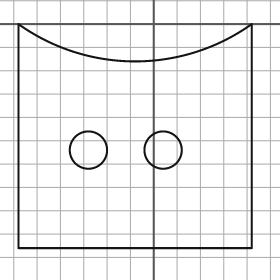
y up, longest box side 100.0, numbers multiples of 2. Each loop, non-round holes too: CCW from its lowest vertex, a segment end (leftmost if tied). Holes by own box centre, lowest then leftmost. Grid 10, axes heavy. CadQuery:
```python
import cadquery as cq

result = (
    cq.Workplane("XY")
    .moveTo(-58.0, -96.0)
    .lineTo(42.0, -96.0)
    .lineTo(42.0, 0.0)
    .threePointArc((-8.0, -16.0), (-58.0, 0.0))
    .close()
    .moveTo(-28.0, -54.0)
    .circle(8.0)
    .moveTo(4.0, -54.0)
    .circle(8.0)
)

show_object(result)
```